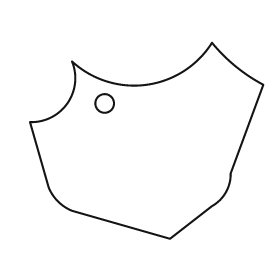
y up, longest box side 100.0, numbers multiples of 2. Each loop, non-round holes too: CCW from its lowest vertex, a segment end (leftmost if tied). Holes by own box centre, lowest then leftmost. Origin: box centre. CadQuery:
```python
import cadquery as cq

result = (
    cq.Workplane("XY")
    .moveTo(10.0, -42.0)
    .lineTo(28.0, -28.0)
    .threePointArc((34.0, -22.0), (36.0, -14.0))
    .lineTo(50.0, 24.0)
    .threePointArc((38.0, 32.0), (28.0, 42.0))
    .threePointArc((0.0, 24.0), (-32.0, 34.0))
    .threePointArc((-34.0, 16.0), (-50.0, 8.0))
    .lineTo(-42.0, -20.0)
    .threePointArc((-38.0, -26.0), (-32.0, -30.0))
    .close()
    .moveTo(-18.0, 16.0)
    .circle(4.0)
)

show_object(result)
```